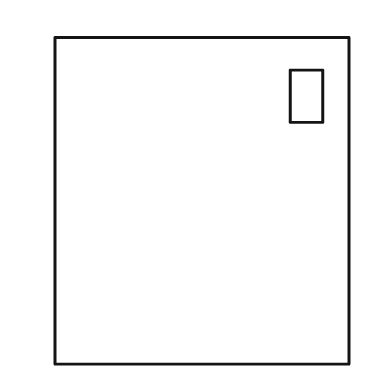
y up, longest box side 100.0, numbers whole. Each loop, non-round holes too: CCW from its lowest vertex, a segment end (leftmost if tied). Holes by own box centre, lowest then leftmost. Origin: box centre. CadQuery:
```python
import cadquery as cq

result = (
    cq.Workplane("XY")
    .moveTo(-45.0, -50.0)
    .lineTo(45.0, -50.0)
    .lineTo(45.0, 50.0)
    .lineTo(-45.0, 50.0)
    .close()
    .moveTo(27.0, 24.0)
    .lineTo(37.0, 24.0)
    .lineTo(37.0, 40.0)
    .lineTo(27.0, 40.0)
    .close()
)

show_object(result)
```